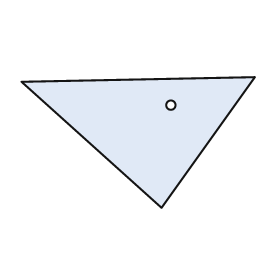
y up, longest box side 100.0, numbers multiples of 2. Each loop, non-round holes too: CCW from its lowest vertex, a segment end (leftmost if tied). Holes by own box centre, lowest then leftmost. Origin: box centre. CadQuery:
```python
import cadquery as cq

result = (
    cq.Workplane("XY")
    .moveTo(10.0, -28.0)
    .lineTo(50.0, 28.0)
    .lineTo(-50.0, 26.0)
    .close()
    .moveTo(14.0, 16.0)
    .circle(2.0)
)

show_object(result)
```